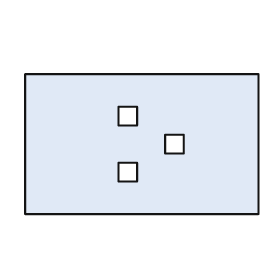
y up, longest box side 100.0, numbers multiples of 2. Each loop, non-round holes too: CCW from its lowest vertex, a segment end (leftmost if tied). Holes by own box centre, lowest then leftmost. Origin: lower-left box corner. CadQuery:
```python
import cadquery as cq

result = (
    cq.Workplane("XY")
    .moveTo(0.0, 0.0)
    .lineTo(100.0, 0.0)
    .lineTo(100.0, 60.0)
    .lineTo(0.0, 60.0)
    .close()
    .moveTo(40.0, 14.0)
    .lineTo(48.0, 14.0)
    .lineTo(48.0, 22.0)
    .lineTo(40.0, 22.0)
    .close()
    .moveTo(60.0, 26.0)
    .lineTo(68.0, 26.0)
    .lineTo(68.0, 34.0)
    .lineTo(60.0, 34.0)
    .close()
    .moveTo(40.0, 38.0)
    .lineTo(48.0, 38.0)
    .lineTo(48.0, 46.0)
    .lineTo(40.0, 46.0)
    .close()
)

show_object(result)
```